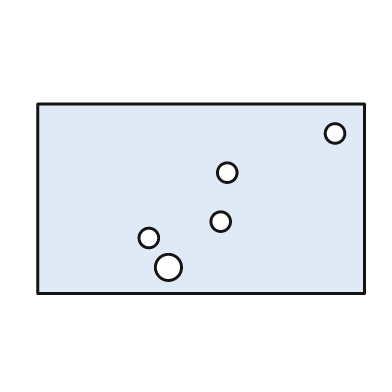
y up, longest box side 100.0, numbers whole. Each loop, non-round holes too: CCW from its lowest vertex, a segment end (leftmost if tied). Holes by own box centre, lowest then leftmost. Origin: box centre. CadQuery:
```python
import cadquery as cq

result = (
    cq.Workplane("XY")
    .moveTo(-50.0, -29.0)
    .lineTo(50.0, -29.0)
    .lineTo(50.0, 29.0)
    .lineTo(-50.0, 29.0)
    .close()
    .moveTo(-10.0, -21.0)
    .circle(4.0)
    .moveTo(-16.0, -12.0)
    .circle(3.0)
    .moveTo(6.0, -7.0)
    .circle(3.0)
    .moveTo(8.0, 8.0)
    .circle(3.0)
    .moveTo(41.0, 20.0)
    .circle(3.0)
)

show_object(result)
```